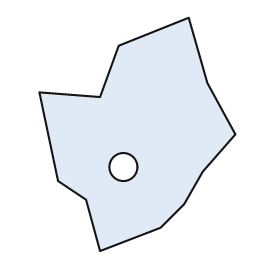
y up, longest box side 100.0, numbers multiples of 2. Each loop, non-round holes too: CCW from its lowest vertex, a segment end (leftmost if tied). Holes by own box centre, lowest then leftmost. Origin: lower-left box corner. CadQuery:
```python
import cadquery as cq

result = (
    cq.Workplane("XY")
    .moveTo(26.0, 0.0)
    .lineTo(52.0, 10.0)
    .lineTo(62.0, 20.0)
    .lineTo(70.0, 34.0)
    .lineTo(84.0, 50.0)
    .lineTo(72.0, 72.0)
    .lineTo(64.0, 100.0)
    .lineTo(34.0, 88.0)
    .lineTo(26.0, 66.0)
    .lineTo(0.0, 68.0)
    .lineTo(8.0, 30.0)
    .lineTo(20.0, 22.0)
    .close()
    .moveTo(36.0, 36.0)
    .circle(6.0)
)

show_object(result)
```